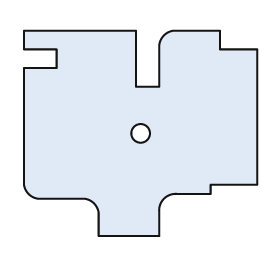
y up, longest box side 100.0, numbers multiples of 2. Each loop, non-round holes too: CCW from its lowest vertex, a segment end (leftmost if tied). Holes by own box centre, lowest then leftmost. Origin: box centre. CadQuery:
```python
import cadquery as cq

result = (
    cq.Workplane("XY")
    .moveTo(-18.0, -44.0)
    .lineTo(8.0, -44.0)
    .lineTo(8.0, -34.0)
    .threePointArc((10.0, -28.0), (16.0, -26.0))
    .lineTo(30.0, -26.0)
    .lineTo(30.0, -22.0)
    .lineTo(50.0, -22.0)
    .lineTo(50.0, 36.0)
    .lineTo(34.0, 36.0)
    .lineTo(34.0, 44.0)
    .lineTo(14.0, 44.0)
    .threePointArc((10.0, 42.0), (8.0, 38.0))
    .lineTo(8.0, 20.0)
    .lineTo(-2.0, 20.0)
    .lineTo(-2.0, 44.0)
    .lineTo(-50.0, 44.0)
    .lineTo(-50.0, 36.0)
    .lineTo(-36.0, 36.0)
    .lineTo(-36.0, 28.0)
    .lineTo(-50.0, 28.0)
    .lineTo(-50.0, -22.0)
    .threePointArc((-48.0, -26.0), (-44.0, -28.0))
    .lineTo(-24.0, -28.0)
    .threePointArc((-20.0, -30.0), (-18.0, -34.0))
    .close()
    .moveTo(0.0, 0.0)
    .circle(4.0)
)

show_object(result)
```